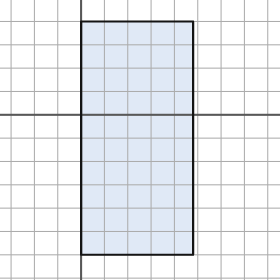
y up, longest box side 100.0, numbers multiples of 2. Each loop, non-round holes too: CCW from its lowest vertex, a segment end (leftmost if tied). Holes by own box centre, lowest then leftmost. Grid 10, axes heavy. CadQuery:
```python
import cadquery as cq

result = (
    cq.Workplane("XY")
    .moveTo(0.0, -60.0)
    .lineTo(48.0, -60.0)
    .lineTo(48.0, 40.0)
    .lineTo(0.0, 40.0)
    .close()
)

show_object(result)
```